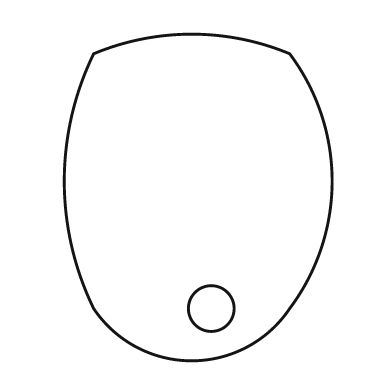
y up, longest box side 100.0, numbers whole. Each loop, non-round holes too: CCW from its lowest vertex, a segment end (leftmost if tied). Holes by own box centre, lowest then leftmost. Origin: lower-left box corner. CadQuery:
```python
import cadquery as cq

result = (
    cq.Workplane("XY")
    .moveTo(9.0, 16.0)
    .threePointArc((39.0, 0.0), (69.0, 16.0))
    .threePointArc((82.0, 55.0), (69.0, 94.0))
    .threePointArc((39.0, 100.0), (9.0, 94.0))
    .threePointArc((0.0, 55.0), (9.0, 16.0))
    .close()
    .moveTo(45.0, 16.0)
    .circle(7.0)
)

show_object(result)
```